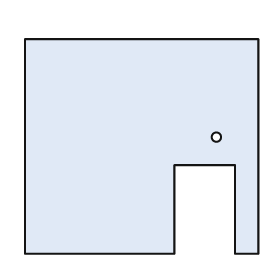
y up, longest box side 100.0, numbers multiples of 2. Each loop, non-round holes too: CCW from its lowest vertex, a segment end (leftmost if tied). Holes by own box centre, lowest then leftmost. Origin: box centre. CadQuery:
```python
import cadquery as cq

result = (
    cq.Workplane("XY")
    .moveTo(-50.0, -46.0)
    .lineTo(14.0, -46.0)
    .lineTo(14.0, -8.0)
    .lineTo(40.0, -8.0)
    .lineTo(40.0, -46.0)
    .lineTo(50.0, -46.0)
    .lineTo(50.0, 46.0)
    .lineTo(-50.0, 46.0)
    .close()
    .moveTo(32.0, 4.0)
    .circle(2.0)
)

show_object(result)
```